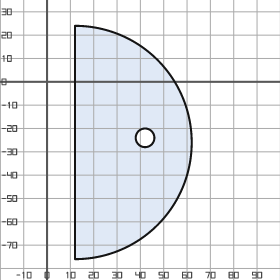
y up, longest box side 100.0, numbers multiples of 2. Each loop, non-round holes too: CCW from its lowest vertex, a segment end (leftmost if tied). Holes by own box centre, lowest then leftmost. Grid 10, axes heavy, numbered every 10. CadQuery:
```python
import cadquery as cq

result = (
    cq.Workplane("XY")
    .moveTo(12.0, -76.0)
    .threePointArc((62.0, -26.0), (12.0, 24.0))
    .close()
    .moveTo(42.0, -24.0)
    .circle(4.0)
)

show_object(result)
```